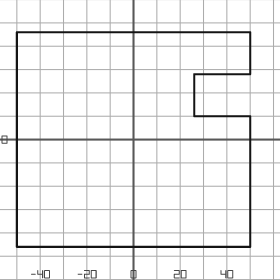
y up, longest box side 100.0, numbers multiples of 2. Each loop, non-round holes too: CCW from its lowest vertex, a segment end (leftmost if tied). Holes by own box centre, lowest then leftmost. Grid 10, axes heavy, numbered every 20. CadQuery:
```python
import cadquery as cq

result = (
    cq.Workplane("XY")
    .moveTo(-50.0, -46.0)
    .lineTo(50.0, -46.0)
    .lineTo(50.0, 10.0)
    .lineTo(26.0, 10.0)
    .lineTo(26.0, 28.0)
    .lineTo(50.0, 28.0)
    .lineTo(50.0, 46.0)
    .lineTo(-50.0, 46.0)
    .close()
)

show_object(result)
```